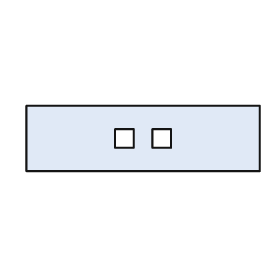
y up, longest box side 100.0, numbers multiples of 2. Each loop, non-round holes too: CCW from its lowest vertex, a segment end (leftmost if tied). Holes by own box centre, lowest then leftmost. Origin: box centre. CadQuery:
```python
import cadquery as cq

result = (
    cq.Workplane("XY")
    .moveTo(-50.0, -14.0)
    .lineTo(50.0, -14.0)
    .lineTo(50.0, 14.0)
    .lineTo(-50.0, 14.0)
    .close()
    .moveTo(-12.0, -4.0)
    .lineTo(-4.0, -4.0)
    .lineTo(-4.0, 4.0)
    .lineTo(-12.0, 4.0)
    .close()
    .moveTo(4.0, -4.0)
    .lineTo(12.0, -4.0)
    .lineTo(12.0, 4.0)
    .lineTo(4.0, 4.0)
    .close()
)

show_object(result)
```